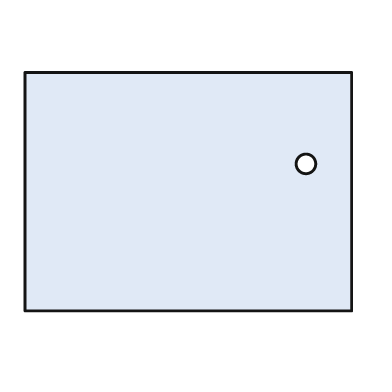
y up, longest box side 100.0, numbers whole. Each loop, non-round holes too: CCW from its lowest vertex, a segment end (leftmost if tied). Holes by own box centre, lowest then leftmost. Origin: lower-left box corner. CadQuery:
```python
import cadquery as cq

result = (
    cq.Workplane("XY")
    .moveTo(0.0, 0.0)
    .lineTo(100.0, 0.0)
    .lineTo(100.0, 73.0)
    .lineTo(0.0, 73.0)
    .close()
    .moveTo(86.0, 45.0)
    .circle(3.0)
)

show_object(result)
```